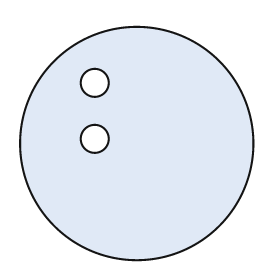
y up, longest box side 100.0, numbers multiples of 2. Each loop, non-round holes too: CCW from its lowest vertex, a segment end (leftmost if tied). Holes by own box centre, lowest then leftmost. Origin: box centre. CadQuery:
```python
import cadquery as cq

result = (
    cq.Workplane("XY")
    .moveTo(0.0, 0.0)
    .circle(50.0)
    .moveTo(-18.0, 2.0)
    .circle(6.0)
    .moveTo(-18.0, 26.0)
    .circle(6.0)
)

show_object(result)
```